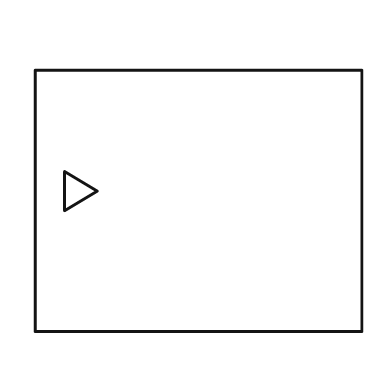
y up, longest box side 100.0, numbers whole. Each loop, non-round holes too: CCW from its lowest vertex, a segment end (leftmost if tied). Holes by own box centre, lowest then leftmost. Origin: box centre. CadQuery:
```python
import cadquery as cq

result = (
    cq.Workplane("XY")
    .moveTo(-50.0, -40.0)
    .lineTo(50.0, -40.0)
    .lineTo(50.0, 40.0)
    .lineTo(-50.0, 40.0)
    .close()
    .moveTo(-41.0, -3.0)
    .lineTo(-31.0, 3.0)
    .lineTo(-41.0, 9.0)
    .close()
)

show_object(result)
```